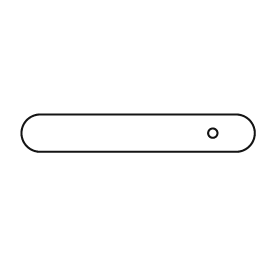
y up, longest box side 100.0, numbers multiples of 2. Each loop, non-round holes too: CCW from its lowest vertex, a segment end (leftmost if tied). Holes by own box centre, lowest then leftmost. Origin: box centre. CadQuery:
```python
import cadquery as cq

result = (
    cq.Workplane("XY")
    .moveTo(-42.0, -8.0)
    .lineTo(42.0, -8.0)
    .threePointArc((50.0, 0.0), (42.0, 8.0))
    .lineTo(-42.0, 8.0)
    .threePointArc((-50.0, 0.0), (-42.0, -8.0))
    .close()
    .moveTo(32.0, 0.0)
    .circle(2.0)
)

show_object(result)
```